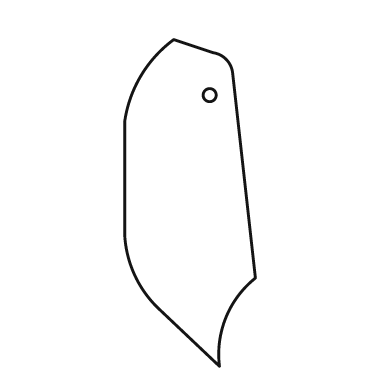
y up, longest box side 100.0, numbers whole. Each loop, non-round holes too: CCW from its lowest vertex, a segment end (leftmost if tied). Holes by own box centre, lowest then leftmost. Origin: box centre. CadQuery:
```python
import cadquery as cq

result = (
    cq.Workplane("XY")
    .moveTo(9.0, -50.0)
    .threePointArc((11.0, -35.0), (20.0, -23.0))
    .lineTo(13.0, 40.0)
    .threePointArc((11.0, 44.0), (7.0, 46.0))
    .lineTo(-5.0, 50.0)
    .threePointArc((-15.0, 39.0), (-20.0, 25.0))
    .lineTo(-20.0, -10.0)
    .threePointArc((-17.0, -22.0), (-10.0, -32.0))
    .close()
    .moveTo(6.0, 33.0)
    .circle(2.0)
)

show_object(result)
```